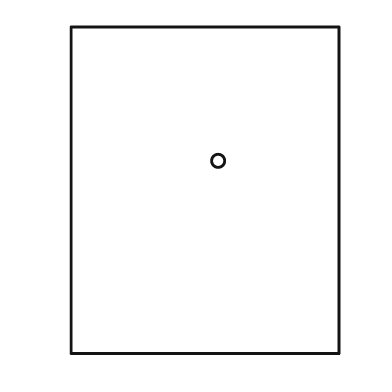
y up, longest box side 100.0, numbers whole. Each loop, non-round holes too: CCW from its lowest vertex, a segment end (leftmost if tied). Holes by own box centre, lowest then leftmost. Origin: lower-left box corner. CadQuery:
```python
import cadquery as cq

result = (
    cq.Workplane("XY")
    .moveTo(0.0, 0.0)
    .lineTo(82.0, 0.0)
    .lineTo(82.0, 100.0)
    .lineTo(0.0, 100.0)
    .close()
    .moveTo(45.0, 59.0)
    .circle(2.0)
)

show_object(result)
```